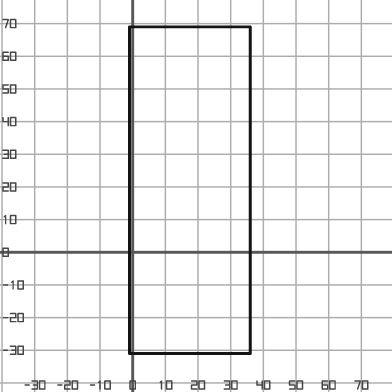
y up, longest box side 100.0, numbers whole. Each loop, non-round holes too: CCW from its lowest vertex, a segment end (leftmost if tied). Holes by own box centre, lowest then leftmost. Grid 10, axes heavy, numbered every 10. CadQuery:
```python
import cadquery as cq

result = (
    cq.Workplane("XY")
    .moveTo(-1.0, -31.0)
    .lineTo(36.0, -31.0)
    .lineTo(36.0, 69.0)
    .lineTo(-1.0, 69.0)
    .close()
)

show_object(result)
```